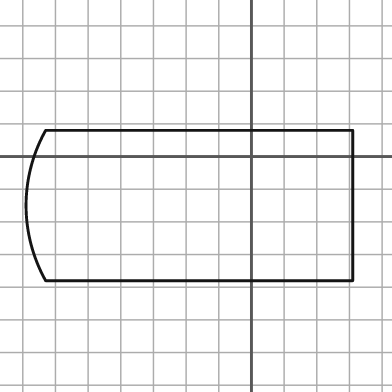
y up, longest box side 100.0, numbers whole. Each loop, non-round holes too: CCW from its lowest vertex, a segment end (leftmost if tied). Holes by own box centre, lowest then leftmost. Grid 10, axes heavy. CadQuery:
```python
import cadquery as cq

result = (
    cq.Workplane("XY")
    .moveTo(-63.0, -38.0)
    .lineTo(31.0, -38.0)
    .lineTo(31.0, 8.0)
    .lineTo(-63.0, 8.0)
    .threePointArc((-69.0, -15.0), (-63.0, -38.0))
    .close()
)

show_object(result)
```